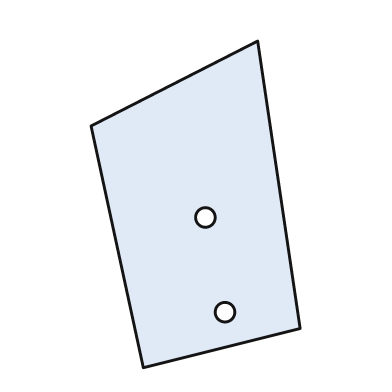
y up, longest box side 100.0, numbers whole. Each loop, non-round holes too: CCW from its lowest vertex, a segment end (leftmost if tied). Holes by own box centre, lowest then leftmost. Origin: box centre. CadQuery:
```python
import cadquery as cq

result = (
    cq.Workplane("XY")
    .moveTo(-16.0, -50.0)
    .lineTo(32.0, -38.0)
    .lineTo(19.0, 50.0)
    .lineTo(-32.0, 24.0)
    .close()
    .moveTo(9.0, -33.0)
    .circle(3.0)
    .moveTo(3.0, -4.0)
    .circle(3.0)
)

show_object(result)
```